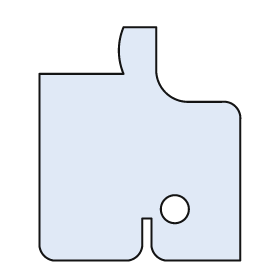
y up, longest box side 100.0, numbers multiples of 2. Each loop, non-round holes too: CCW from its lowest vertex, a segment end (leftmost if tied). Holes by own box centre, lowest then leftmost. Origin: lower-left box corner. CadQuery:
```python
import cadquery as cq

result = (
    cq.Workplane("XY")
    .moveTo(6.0, 0.0)
    .lineTo(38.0, 0.0)
    .threePointArc((42.0, 2.0), (44.0, 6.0))
    .lineTo(44.0, 18.0)
    .lineTo(48.0, 18.0)
    .lineTo(48.0, 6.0)
    .threePointArc((50.0, 2.0), (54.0, 0.0))
    .lineTo(86.0, 0.0)
    .lineTo(86.0, 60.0)
    .threePointArc((84.0, 66.0), (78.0, 68.0))
    .lineTo(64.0, 68.0)
    .threePointArc((54.0, 72.0), (50.0, 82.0))
    .lineTo(50.0, 100.0)
    .lineTo(36.0, 100.0)
    .threePointArc((34.0, 90.0), (36.0, 80.0))
    .lineTo(0.0, 80.0)
    .lineTo(0.0, 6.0)
    .threePointArc((2.0, 2.0), (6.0, 0.0))
    .close()
    .moveTo(58.0, 22.0)
    .circle(6.0)
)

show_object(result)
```